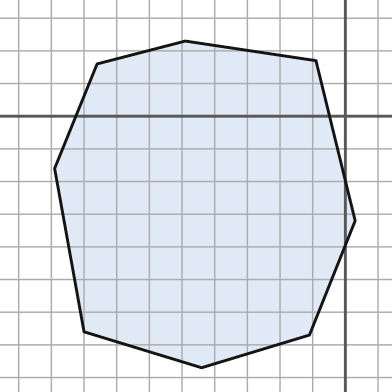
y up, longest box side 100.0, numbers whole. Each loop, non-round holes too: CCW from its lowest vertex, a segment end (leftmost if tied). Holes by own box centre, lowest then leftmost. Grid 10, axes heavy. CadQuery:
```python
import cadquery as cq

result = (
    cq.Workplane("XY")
    .moveTo(-44.0, -77.0)
    .lineTo(-11.0, -67.0)
    .lineTo(3.0, -32.0)
    .lineTo(-9.0, 17.0)
    .lineTo(-49.0, 23.0)
    .lineTo(-76.0, 16.0)
    .lineTo(-89.0, -16.0)
    .lineTo(-80.0, -66.0)
    .close()
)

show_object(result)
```